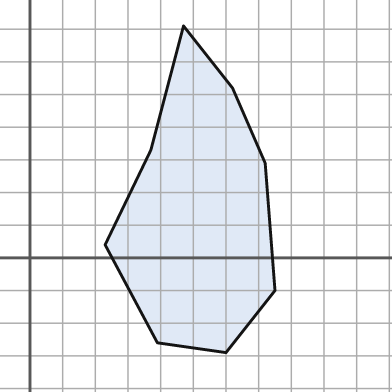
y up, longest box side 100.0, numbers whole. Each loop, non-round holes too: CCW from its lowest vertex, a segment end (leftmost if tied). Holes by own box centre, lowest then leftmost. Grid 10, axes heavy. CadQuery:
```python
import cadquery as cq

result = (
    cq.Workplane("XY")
    .moveTo(60.0, -29.0)
    .lineTo(75.0, -10.0)
    .lineTo(72.0, 29.0)
    .lineTo(62.0, 52.0)
    .lineTo(47.0, 71.0)
    .lineTo(37.0, 33.0)
    .lineTo(23.0, 4.0)
    .lineTo(39.0, -26.0)
    .close()
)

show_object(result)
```